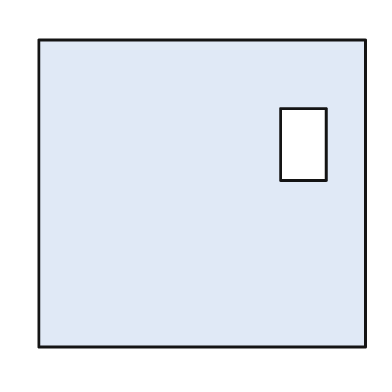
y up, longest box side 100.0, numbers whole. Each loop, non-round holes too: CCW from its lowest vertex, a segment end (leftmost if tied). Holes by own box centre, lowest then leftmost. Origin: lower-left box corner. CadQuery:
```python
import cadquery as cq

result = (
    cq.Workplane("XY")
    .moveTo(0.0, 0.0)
    .lineTo(100.0, 0.0)
    .lineTo(100.0, 94.0)
    .lineTo(0.0, 94.0)
    .close()
    .moveTo(74.0, 51.0)
    .lineTo(88.0, 51.0)
    .lineTo(88.0, 73.0)
    .lineTo(74.0, 73.0)
    .close()
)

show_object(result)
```